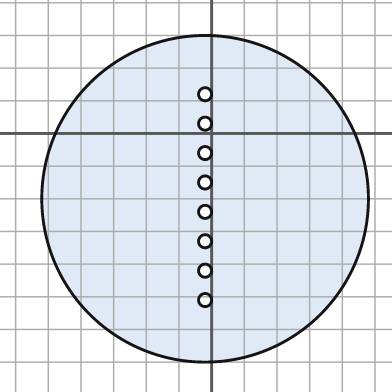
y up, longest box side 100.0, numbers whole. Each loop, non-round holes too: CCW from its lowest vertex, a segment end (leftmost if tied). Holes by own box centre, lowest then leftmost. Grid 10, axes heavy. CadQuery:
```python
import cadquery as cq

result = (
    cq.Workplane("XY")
    .moveTo(-2.0, -20.0)
    .circle(50.0)
    .moveTo(-2.0, -51.0)
    .circle(2.0)
    .moveTo(-2.0, -42.0)
    .circle(2.0)
    .moveTo(-2.0, -33.0)
    .circle(2.0)
    .moveTo(-2.0, -24.0)
    .circle(2.0)
    .moveTo(-2.0, -15.0)
    .circle(2.0)
    .moveTo(-2.0, -6.0)
    .circle(2.0)
    .moveTo(-2.0, 3.0)
    .circle(2.0)
    .moveTo(-2.0, 12.0)
    .circle(2.0)
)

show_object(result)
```